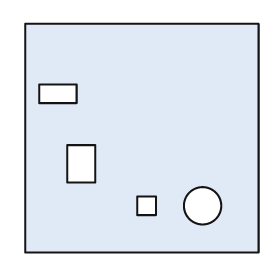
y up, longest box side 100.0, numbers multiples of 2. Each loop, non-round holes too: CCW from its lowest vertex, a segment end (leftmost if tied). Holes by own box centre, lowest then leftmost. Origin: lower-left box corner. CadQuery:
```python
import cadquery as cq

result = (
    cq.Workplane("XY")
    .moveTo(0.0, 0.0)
    .lineTo(100.0, 0.0)
    .lineTo(100.0, 98.0)
    .lineTo(0.0, 98.0)
    .close()
    .moveTo(48.0, 16.0)
    .lineTo(56.0, 16.0)
    .lineTo(56.0, 24.0)
    .lineTo(48.0, 24.0)
    .close()
    .moveTo(76.0, 20.0)
    .circle(8.0)
    .moveTo(18.0, 30.0)
    .lineTo(30.0, 30.0)
    .lineTo(30.0, 46.0)
    .lineTo(18.0, 46.0)
    .close()
    .moveTo(6.0, 64.0)
    .lineTo(22.0, 64.0)
    .lineTo(22.0, 72.0)
    .lineTo(6.0, 72.0)
    .close()
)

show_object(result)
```